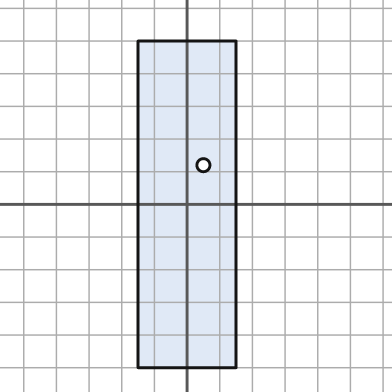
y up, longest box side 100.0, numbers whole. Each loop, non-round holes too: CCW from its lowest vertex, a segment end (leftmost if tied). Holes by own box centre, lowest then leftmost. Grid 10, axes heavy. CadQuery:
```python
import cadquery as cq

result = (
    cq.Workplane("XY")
    .moveTo(-15.0, -50.0)
    .lineTo(15.0, -50.0)
    .lineTo(15.0, 50.0)
    .lineTo(-15.0, 50.0)
    .close()
    .moveTo(5.0, 12.0)
    .circle(2.0)
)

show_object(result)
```